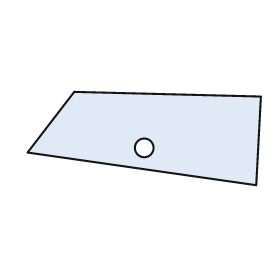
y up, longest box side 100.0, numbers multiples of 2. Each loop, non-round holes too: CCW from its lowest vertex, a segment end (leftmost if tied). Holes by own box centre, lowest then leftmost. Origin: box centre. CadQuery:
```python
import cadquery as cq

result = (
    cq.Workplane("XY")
    .moveTo(48.0, -20.0)
    .lineTo(50.0, 18.0)
    .lineTo(-30.0, 20.0)
    .lineTo(-50.0, -6.0)
    .close()
    .moveTo(0.0, -4.0)
    .circle(4.0)
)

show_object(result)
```